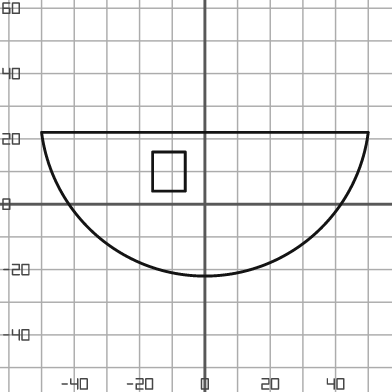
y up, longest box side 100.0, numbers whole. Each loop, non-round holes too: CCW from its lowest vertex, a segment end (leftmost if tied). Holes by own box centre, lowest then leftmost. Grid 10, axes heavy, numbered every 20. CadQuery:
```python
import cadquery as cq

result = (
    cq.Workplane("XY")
    .moveTo(-50.0, 22.0)
    .threePointArc((0.0, -22.0), (50.0, 22.0))
    .close()
    .moveTo(-16.0, 4.0)
    .lineTo(-6.0, 4.0)
    .lineTo(-6.0, 16.0)
    .lineTo(-16.0, 16.0)
    .close()
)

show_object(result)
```